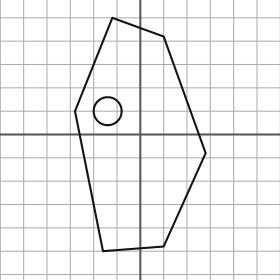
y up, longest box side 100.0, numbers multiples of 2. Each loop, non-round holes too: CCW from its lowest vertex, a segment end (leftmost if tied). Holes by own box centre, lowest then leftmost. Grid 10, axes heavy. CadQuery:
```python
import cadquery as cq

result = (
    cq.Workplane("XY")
    .moveTo(-16.0, -50.0)
    .lineTo(10.0, -48.0)
    .lineTo(28.0, -8.0)
    .lineTo(10.0, 42.0)
    .lineTo(-12.0, 50.0)
    .lineTo(-28.0, 10.0)
    .close()
    .moveTo(-14.0, 10.0)
    .circle(6.0)
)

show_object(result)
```